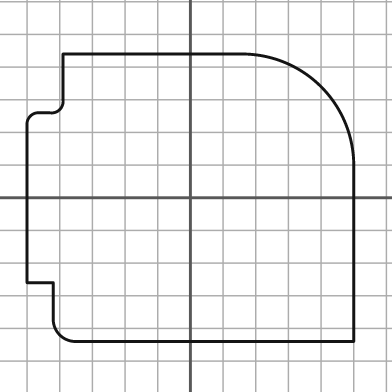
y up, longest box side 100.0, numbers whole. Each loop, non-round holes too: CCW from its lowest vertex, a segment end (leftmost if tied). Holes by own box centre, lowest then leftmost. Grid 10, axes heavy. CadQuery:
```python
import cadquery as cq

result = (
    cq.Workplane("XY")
    .moveTo(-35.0, -44.0)
    .lineTo(50.0, -44.0)
    .lineTo(50.0, 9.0)
    .threePointArc((40.0, 34.0), (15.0, 44.0))
    .lineTo(-39.0, 44.0)
    .lineTo(-39.0, 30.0)
    .threePointArc((-40.0, 27.0), (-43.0, 26.0))
    .lineTo(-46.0, 26.0)
    .threePointArc((-49.0, 25.0), (-50.0, 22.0))
    .lineTo(-50.0, -26.0)
    .lineTo(-42.0, -26.0)
    .lineTo(-42.0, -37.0)
    .threePointArc((-40.0, -42.0), (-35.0, -44.0))
    .close()
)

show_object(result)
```